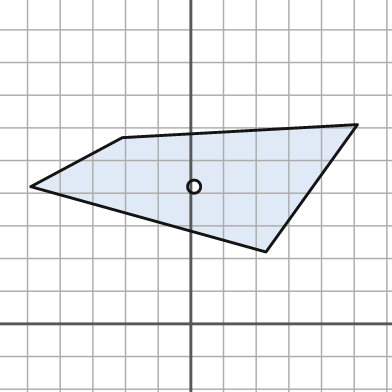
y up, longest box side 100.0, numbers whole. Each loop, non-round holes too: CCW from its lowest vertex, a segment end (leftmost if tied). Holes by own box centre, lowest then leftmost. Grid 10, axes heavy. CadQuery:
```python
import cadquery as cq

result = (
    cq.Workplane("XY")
    .moveTo(23.0, 22.0)
    .lineTo(51.0, 61.0)
    .lineTo(-21.0, 57.0)
    .lineTo(-49.0, 42.0)
    .close()
    .moveTo(1.0, 42.0)
    .circle(2.0)
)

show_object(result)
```